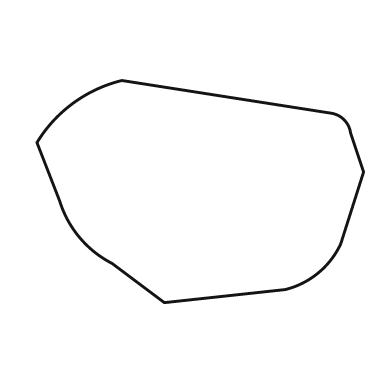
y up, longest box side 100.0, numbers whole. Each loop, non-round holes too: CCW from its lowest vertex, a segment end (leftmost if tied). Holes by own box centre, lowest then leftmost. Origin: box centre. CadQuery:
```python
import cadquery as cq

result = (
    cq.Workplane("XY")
    .moveTo(-11.0, -34.0)
    .lineTo(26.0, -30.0)
    .threePointArc((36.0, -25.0), (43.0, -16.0))
    .lineTo(50.0, 6.0)
    .lineTo(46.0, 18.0)
    .threePointArc((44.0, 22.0), (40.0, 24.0))
    .lineTo(-24.0, 34.0)
    .threePointArc((-39.0, 27.0), (-50.0, 15.0))
    .lineTo(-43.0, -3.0)
    .threePointArc((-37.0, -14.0), (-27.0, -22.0))
    .close()
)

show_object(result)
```